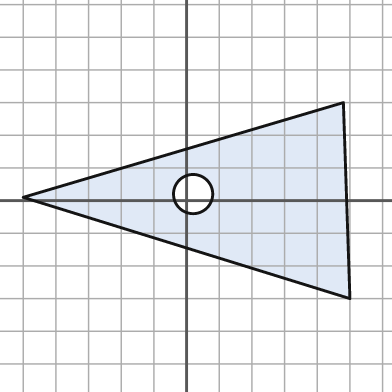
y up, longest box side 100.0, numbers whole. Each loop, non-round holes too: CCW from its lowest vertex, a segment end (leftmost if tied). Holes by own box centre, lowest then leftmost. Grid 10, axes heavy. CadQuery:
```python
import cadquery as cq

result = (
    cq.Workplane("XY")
    .moveTo(50.0, -30.0)
    .lineTo(48.0, 30.0)
    .lineTo(-50.0, 1.0)
    .close()
    .moveTo(2.0, 2.0)
    .circle(6.0)
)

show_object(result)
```